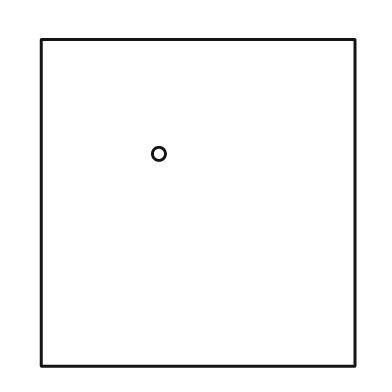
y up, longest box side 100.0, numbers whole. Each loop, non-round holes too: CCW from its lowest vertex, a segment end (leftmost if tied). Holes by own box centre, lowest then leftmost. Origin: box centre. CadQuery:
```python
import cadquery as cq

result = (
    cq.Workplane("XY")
    .moveTo(-48.0, -50.0)
    .lineTo(48.0, -50.0)
    .lineTo(48.0, 50.0)
    .lineTo(-48.0, 50.0)
    .close()
    .moveTo(-12.0, 15.0)
    .circle(2.0)
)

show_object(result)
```